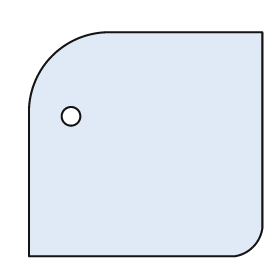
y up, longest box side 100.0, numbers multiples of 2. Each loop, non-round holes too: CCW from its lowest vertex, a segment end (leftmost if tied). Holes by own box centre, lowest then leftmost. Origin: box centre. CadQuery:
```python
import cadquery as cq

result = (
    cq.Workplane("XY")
    .moveTo(-50.0, -48.0)
    .lineTo(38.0, -48.0)
    .threePointArc((46.0, -44.0), (50.0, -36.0))
    .lineTo(50.0, 48.0)
    .lineTo(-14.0, 48.0)
    .threePointArc((-40.0, 38.0), (-50.0, 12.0))
    .close()
    .moveTo(-32.0, 12.0)
    .circle(4.0)
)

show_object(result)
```